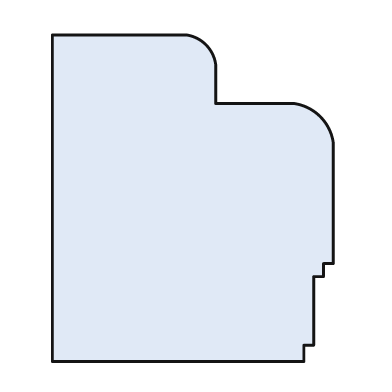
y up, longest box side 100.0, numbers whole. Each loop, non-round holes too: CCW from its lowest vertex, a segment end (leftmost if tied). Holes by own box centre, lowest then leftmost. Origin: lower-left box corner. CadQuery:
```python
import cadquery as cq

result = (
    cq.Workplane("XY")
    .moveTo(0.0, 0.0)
    .lineTo(77.0, 0.0)
    .lineTo(77.0, 5.0)
    .lineTo(80.0, 5.0)
    .lineTo(80.0, 26.0)
    .lineTo(83.0, 26.0)
    .lineTo(83.0, 30.0)
    .lineTo(86.0, 30.0)
    .lineTo(86.0, 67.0)
    .threePointArc((82.0, 75.0), (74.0, 79.0))
    .lineTo(50.0, 79.0)
    .lineTo(50.0, 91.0)
    .threePointArc((47.0, 97.0), (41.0, 100.0))
    .lineTo(0.0, 100.0)
    .close()
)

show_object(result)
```